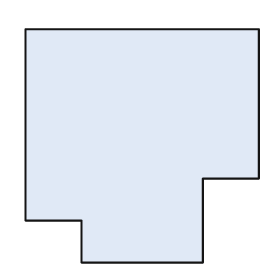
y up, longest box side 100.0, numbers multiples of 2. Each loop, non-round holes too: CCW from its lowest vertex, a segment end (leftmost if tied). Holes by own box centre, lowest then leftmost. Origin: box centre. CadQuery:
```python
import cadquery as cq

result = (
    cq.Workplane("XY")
    .moveTo(-26.0, -50.0)
    .lineTo(26.0, -50.0)
    .lineTo(26.0, -14.0)
    .lineTo(50.0, -14.0)
    .lineTo(50.0, 50.0)
    .lineTo(-50.0, 50.0)
    .lineTo(-50.0, -32.0)
    .lineTo(-26.0, -32.0)
    .close()
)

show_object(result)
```